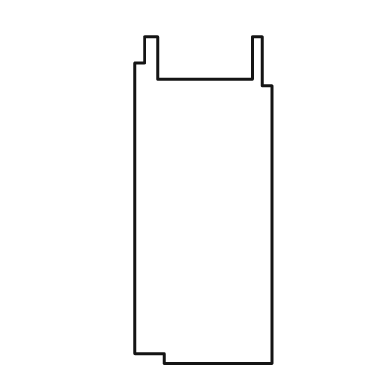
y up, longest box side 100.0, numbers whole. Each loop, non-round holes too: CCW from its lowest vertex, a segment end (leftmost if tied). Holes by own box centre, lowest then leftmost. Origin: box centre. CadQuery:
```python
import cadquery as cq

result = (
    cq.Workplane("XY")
    .moveTo(-12.0, -50.0)
    .lineTo(21.0, -50.0)
    .lineTo(21.0, 35.0)
    .lineTo(18.0, 35.0)
    .lineTo(18.0, 50.0)
    .lineTo(15.0, 50.0)
    .lineTo(15.0, 37.0)
    .lineTo(-14.0, 37.0)
    .lineTo(-14.0, 50.0)
    .lineTo(-18.0, 50.0)
    .lineTo(-18.0, 42.0)
    .lineTo(-21.0, 42.0)
    .lineTo(-21.0, -47.0)
    .lineTo(-12.0, -47.0)
    .close()
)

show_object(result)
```